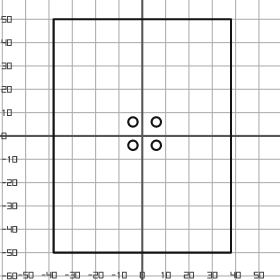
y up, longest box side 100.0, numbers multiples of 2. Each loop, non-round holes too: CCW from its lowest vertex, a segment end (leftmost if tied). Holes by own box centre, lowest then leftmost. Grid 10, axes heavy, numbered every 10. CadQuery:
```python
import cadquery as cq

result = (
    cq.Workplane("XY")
    .moveTo(-38.0, -50.0)
    .lineTo(38.0, -50.0)
    .lineTo(38.0, 50.0)
    .lineTo(-38.0, 50.0)
    .close()
    .moveTo(-4.0, -4.0)
    .circle(2.0)
    .moveTo(6.0, -4.0)
    .circle(2.0)
    .moveTo(-4.0, 6.0)
    .circle(2.0)
    .moveTo(6.0, 6.0)
    .circle(2.0)
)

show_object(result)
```